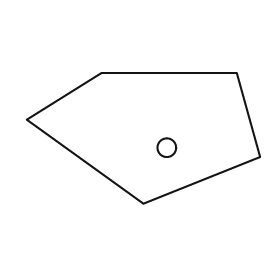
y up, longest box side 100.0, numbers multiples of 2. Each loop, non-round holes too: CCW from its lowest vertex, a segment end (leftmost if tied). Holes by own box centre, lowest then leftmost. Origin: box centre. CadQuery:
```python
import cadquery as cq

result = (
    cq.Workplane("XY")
    .moveTo(0.0, -28.0)
    .lineTo(50.0, -8.0)
    .lineTo(40.0, 28.0)
    .lineTo(-18.0, 28.0)
    .lineTo(-50.0, 8.0)
    .close()
    .moveTo(10.0, -4.0)
    .circle(4.0)
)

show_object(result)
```